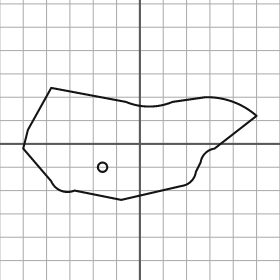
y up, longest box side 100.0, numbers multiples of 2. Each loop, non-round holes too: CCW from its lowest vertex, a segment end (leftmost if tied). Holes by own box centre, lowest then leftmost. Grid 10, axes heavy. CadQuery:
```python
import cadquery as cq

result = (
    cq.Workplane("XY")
    .moveTo(-8.0, -24.0)
    .lineTo(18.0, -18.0)
    .threePointArc((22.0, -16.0), (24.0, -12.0))
    .lineTo(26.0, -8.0)
    .threePointArc((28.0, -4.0), (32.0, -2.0))
    .lineTo(50.0, 12.0)
    .threePointArc((40.0, 18.0), (28.0, 20.0))
    .lineTo(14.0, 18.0)
    .threePointArc((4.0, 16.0), (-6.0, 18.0))
    .lineTo(-38.0, 24.0)
    .lineTo(-48.0, 6.0)
    .lineTo(-50.0, -2.0)
    .lineTo(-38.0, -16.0)
    .threePointArc((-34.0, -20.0), (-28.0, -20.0))
    .close()
    .moveTo(-16.0, -10.0)
    .circle(2.0)
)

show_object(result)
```